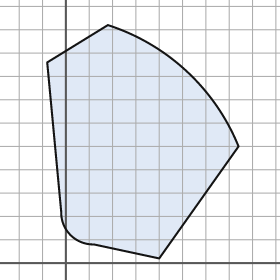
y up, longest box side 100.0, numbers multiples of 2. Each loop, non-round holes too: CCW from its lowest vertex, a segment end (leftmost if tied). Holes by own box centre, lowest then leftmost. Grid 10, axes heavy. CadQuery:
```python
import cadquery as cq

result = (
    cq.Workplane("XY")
    .moveTo(40.0, 2.0)
    .lineTo(74.0, 50.0)
    .threePointArc((52.0, 82.0), (18.0, 102.0))
    .lineTo(-8.0, 86.0)
    .lineTo(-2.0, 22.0)
    .threePointArc((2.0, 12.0), (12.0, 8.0))
    .close()
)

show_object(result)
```